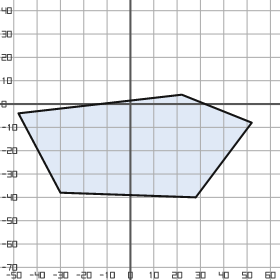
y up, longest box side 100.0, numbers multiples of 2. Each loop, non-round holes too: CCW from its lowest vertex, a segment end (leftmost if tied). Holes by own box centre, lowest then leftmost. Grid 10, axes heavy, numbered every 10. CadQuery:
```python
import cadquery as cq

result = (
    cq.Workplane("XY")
    .moveTo(28.0, -40.0)
    .lineTo(52.0, -8.0)
    .lineTo(22.0, 4.0)
    .lineTo(-48.0, -4.0)
    .lineTo(-30.0, -38.0)
    .close()
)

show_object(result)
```